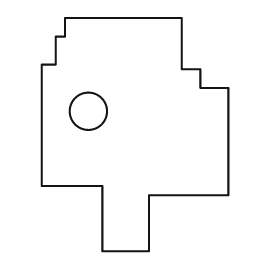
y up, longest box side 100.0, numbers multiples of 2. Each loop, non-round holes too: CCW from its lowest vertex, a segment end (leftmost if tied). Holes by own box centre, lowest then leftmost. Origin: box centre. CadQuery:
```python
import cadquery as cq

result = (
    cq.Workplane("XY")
    .moveTo(-14.0, -50.0)
    .lineTo(6.0, -50.0)
    .lineTo(6.0, -26.0)
    .lineTo(40.0, -26.0)
    .lineTo(40.0, 20.0)
    .lineTo(28.0, 20.0)
    .lineTo(28.0, 28.0)
    .lineTo(20.0, 28.0)
    .lineTo(20.0, 50.0)
    .lineTo(-30.0, 50.0)
    .lineTo(-30.0, 42.0)
    .lineTo(-34.0, 42.0)
    .lineTo(-34.0, 30.0)
    .lineTo(-40.0, 30.0)
    .lineTo(-40.0, -22.0)
    .lineTo(-14.0, -22.0)
    .close()
    .moveTo(-20.0, 10.0)
    .circle(8.0)
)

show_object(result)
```